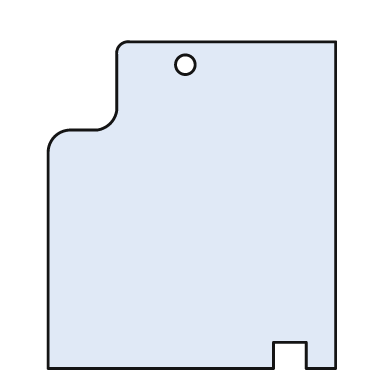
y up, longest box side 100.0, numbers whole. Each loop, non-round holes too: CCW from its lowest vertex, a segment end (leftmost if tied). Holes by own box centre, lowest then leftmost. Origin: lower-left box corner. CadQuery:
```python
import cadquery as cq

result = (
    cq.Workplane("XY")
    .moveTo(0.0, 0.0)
    .lineTo(69.0, 0.0)
    .lineTo(69.0, 8.0)
    .lineTo(79.0, 8.0)
    .lineTo(79.0, 0.0)
    .lineTo(88.0, 0.0)
    .lineTo(88.0, 100.0)
    .lineTo(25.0, 100.0)
    .threePointArc((22.0, 99.0), (21.0, 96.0))
    .lineTo(21.0, 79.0)
    .threePointArc((19.0, 75.0), (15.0, 73.0))
    .lineTo(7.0, 73.0)
    .threePointArc((2.0, 71.0), (0.0, 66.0))
    .close()
    .moveTo(42.0, 93.0)
    .circle(3.0)
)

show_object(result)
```